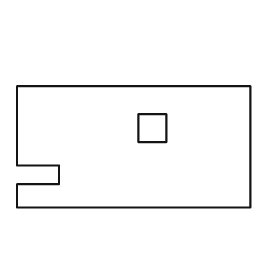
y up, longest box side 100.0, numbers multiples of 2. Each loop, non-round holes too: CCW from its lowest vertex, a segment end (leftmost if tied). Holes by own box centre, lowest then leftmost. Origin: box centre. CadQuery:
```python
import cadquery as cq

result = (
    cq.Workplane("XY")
    .moveTo(-50.0, -26.0)
    .lineTo(50.0, -26.0)
    .lineTo(50.0, 26.0)
    .lineTo(-50.0, 26.0)
    .lineTo(-50.0, -8.0)
    .lineTo(-32.0, -8.0)
    .lineTo(-32.0, -16.0)
    .lineTo(-50.0, -16.0)
    .close()
    .moveTo(2.0, 2.0)
    .lineTo(14.0, 2.0)
    .lineTo(14.0, 14.0)
    .lineTo(2.0, 14.0)
    .close()
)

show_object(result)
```